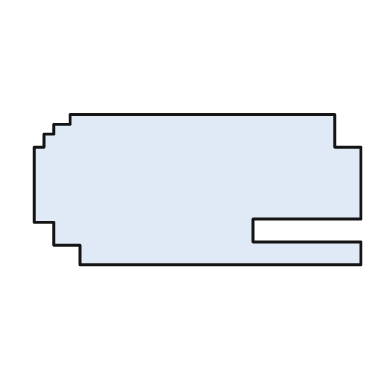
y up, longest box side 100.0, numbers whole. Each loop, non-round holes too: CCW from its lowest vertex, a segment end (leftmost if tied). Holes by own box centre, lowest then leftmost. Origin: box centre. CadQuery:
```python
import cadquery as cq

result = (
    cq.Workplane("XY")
    .moveTo(-36.0, -23.0)
    .lineTo(50.0, -23.0)
    .lineTo(50.0, -16.0)
    .lineTo(17.0, -16.0)
    .lineTo(17.0, -9.0)
    .lineTo(50.0, -9.0)
    .lineTo(50.0, 13.0)
    .lineTo(42.0, 13.0)
    .lineTo(42.0, 23.0)
    .lineTo(-39.0, 23.0)
    .lineTo(-39.0, 20.0)
    .lineTo(-44.0, 20.0)
    .lineTo(-44.0, 17.0)
    .lineTo(-47.0, 17.0)
    .lineTo(-47.0, 13.0)
    .lineTo(-50.0, 13.0)
    .lineTo(-50.0, -10.0)
    .lineTo(-44.0, -10.0)
    .lineTo(-44.0, -17.0)
    .lineTo(-36.0, -17.0)
    .close()
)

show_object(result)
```